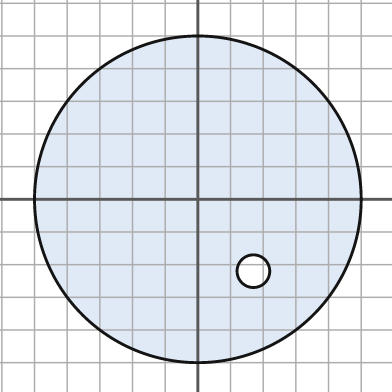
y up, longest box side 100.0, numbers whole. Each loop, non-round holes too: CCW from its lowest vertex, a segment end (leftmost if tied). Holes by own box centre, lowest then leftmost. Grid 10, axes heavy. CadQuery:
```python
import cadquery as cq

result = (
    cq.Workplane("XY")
    .moveTo(0.0, 0.0)
    .circle(50.0)
    .moveTo(17.0, -22.0)
    .circle(5.0)
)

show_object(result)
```